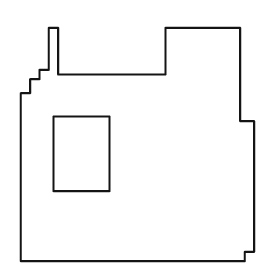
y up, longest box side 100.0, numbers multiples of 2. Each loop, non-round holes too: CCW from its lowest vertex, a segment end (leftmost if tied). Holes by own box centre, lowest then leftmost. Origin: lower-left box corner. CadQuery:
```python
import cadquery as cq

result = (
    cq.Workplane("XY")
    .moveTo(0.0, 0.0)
    .lineTo(96.0, 0.0)
    .lineTo(96.0, 4.0)
    .lineTo(100.0, 4.0)
    .lineTo(100.0, 60.0)
    .lineTo(94.0, 60.0)
    .lineTo(94.0, 100.0)
    .lineTo(62.0, 100.0)
    .lineTo(62.0, 80.0)
    .lineTo(16.0, 80.0)
    .lineTo(16.0, 100.0)
    .lineTo(12.0, 100.0)
    .lineTo(12.0, 82.0)
    .lineTo(8.0, 82.0)
    .lineTo(8.0, 78.0)
    .lineTo(4.0, 78.0)
    .lineTo(4.0, 72.0)
    .lineTo(0.0, 72.0)
    .close()
    .moveTo(14.0, 30.0)
    .lineTo(38.0, 30.0)
    .lineTo(38.0, 62.0)
    .lineTo(14.0, 62.0)
    .close()
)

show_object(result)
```